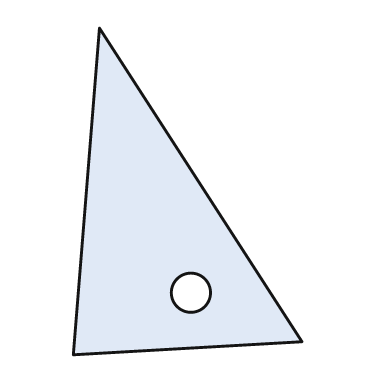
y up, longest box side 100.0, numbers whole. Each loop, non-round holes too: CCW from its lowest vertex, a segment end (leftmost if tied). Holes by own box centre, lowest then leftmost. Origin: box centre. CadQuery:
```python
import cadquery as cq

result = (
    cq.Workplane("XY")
    .moveTo(-35.0, -50.0)
    .lineTo(35.0, -46.0)
    .lineTo(-27.0, 50.0)
    .close()
    .moveTo(1.0, -31.0)
    .circle(6.0)
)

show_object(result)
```